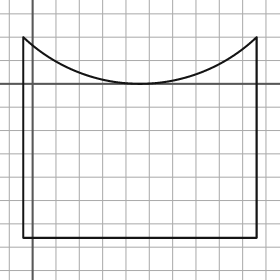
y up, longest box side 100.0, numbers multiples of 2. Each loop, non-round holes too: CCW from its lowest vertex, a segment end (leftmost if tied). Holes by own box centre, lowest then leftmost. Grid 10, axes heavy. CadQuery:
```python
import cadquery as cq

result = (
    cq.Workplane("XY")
    .moveTo(-4.0, -66.0)
    .lineTo(96.0, -66.0)
    .lineTo(96.0, 20.0)
    .threePointArc((46.0, 0.0), (-4.0, 20.0))
    .close()
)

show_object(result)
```